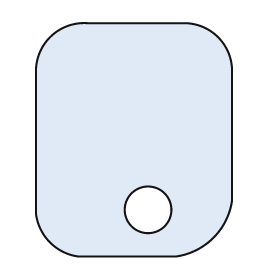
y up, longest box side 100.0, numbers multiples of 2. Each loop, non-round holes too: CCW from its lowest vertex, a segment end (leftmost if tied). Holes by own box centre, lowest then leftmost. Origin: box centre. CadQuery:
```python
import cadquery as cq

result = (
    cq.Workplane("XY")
    .moveTo(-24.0, -50.0)
    .lineTo(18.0, -50.0)
    .threePointArc((34.0, -42.0), (42.0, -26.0))
    .lineTo(42.0, 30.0)
    .threePointArc((36.0, 44.0), (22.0, 50.0))
    .lineTo(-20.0, 50.0)
    .threePointArc((-36.0, 44.0), (-42.0, 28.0))
    .lineTo(-42.0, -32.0)
    .threePointArc((-36.0, -44.0), (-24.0, -50.0))
    .close()
    .moveTo(6.0, -30.0)
    .circle(10.0)
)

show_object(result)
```